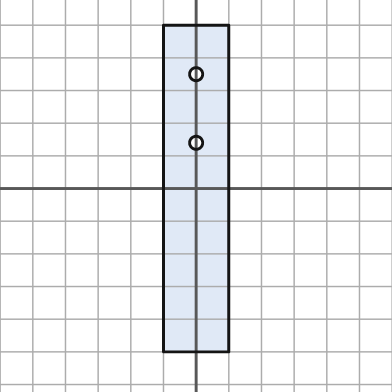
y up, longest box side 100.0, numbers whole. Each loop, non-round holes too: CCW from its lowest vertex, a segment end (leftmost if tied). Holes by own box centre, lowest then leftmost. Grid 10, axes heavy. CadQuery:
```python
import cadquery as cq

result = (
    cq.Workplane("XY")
    .moveTo(-10.0, -50.0)
    .lineTo(10.0, -50.0)
    .lineTo(10.0, 50.0)
    .lineTo(-10.0, 50.0)
    .close()
    .moveTo(0.0, 14.0)
    .circle(2.0)
    .moveTo(0.0, 35.0)
    .circle(2.0)
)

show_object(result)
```